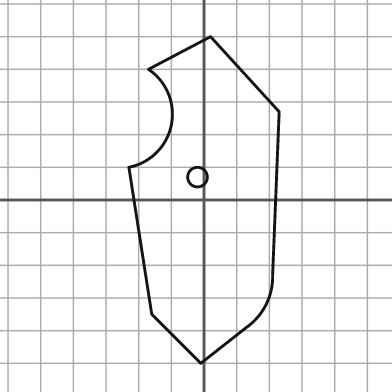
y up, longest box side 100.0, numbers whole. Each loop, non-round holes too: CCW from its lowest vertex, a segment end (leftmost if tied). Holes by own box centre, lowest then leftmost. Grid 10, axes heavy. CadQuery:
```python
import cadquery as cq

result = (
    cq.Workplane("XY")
    .moveTo(-1.0, -50.0)
    .lineTo(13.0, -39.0)
    .threePointArc((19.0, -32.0), (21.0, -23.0))
    .lineTo(23.0, 27.0)
    .lineTo(2.0, 50.0)
    .lineTo(-17.0, 40.0)
    .threePointArc((-10.0, 23.0), (-23.0, 10.0))
    .lineTo(-16.0, -35.0)
    .close()
    .moveTo(-2.0, 7.0)
    .circle(3.0)
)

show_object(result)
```